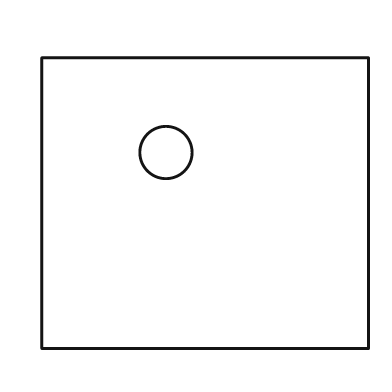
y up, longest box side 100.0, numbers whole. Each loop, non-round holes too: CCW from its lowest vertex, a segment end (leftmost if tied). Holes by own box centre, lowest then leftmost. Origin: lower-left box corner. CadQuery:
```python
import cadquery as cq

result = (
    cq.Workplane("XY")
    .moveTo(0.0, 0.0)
    .lineTo(100.0, 0.0)
    .lineTo(100.0, 89.0)
    .lineTo(0.0, 89.0)
    .close()
    .moveTo(38.0, 60.0)
    .circle(8.0)
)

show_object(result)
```